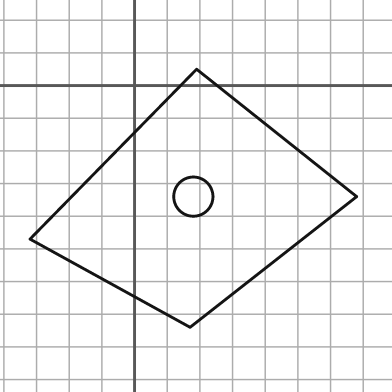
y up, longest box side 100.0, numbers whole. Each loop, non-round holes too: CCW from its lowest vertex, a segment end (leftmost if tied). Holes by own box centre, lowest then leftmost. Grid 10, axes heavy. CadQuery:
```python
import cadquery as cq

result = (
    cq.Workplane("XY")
    .moveTo(17.0, -74.0)
    .lineTo(68.0, -34.0)
    .lineTo(19.0, 5.0)
    .lineTo(-32.0, -47.0)
    .close()
    .moveTo(18.0, -34.0)
    .circle(6.0)
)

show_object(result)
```